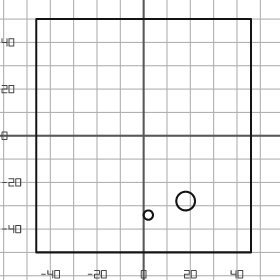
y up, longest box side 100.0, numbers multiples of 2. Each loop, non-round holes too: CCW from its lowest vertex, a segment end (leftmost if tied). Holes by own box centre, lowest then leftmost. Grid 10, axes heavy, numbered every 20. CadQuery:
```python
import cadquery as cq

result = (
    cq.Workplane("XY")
    .moveTo(-46.0, -50.0)
    .lineTo(46.0, -50.0)
    .lineTo(46.0, 50.0)
    .lineTo(-46.0, 50.0)
    .close()
    .moveTo(2.0, -34.0)
    .circle(2.0)
    .moveTo(18.0, -28.0)
    .circle(4.0)
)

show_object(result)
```